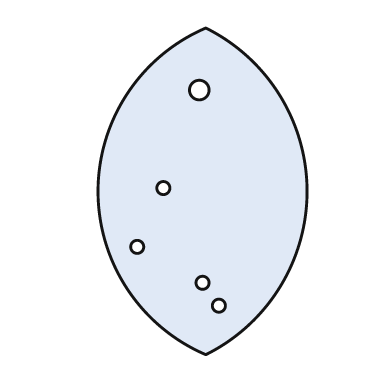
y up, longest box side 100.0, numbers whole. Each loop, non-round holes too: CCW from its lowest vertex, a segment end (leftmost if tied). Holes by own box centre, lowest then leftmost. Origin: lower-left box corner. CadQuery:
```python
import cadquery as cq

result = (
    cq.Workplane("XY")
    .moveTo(33.0, 0.0)
    .threePointArc((64.0, 50.0), (33.0, 100.0))
    .threePointArc((0.0, 50.0), (33.0, 0.0))
    .close()
    .moveTo(37.0, 15.0)
    .circle(2.0)
    .moveTo(32.0, 22.0)
    .circle(2.0)
    .moveTo(12.0, 33.0)
    .circle(2.0)
    .moveTo(20.0, 51.0)
    .circle(2.0)
    .moveTo(31.0, 81.0)
    .circle(3.0)
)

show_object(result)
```